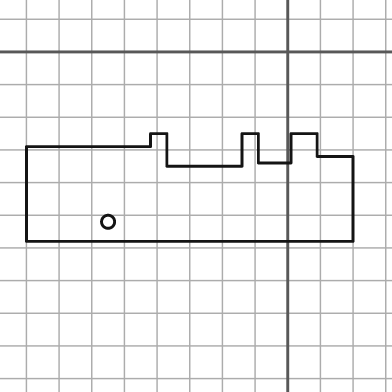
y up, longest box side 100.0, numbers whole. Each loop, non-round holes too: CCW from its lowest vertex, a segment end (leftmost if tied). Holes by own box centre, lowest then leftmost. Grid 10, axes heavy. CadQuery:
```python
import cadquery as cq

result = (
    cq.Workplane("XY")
    .moveTo(-80.0, -58.0)
    .lineTo(20.0, -58.0)
    .lineTo(20.0, -32.0)
    .lineTo(9.0, -32.0)
    .lineTo(9.0, -25.0)
    .lineTo(1.0, -25.0)
    .lineTo(1.0, -34.0)
    .lineTo(-9.0, -34.0)
    .lineTo(-9.0, -25.0)
    .lineTo(-14.0, -25.0)
    .lineTo(-14.0, -35.0)
    .lineTo(-37.0, -35.0)
    .lineTo(-37.0, -25.0)
    .lineTo(-42.0, -25.0)
    .lineTo(-42.0, -29.0)
    .lineTo(-80.0, -29.0)
    .close()
    .moveTo(-55.0, -52.0)
    .circle(2.0)
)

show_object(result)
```